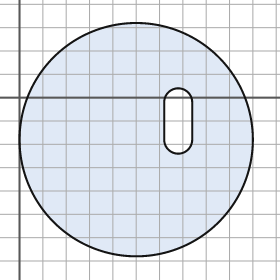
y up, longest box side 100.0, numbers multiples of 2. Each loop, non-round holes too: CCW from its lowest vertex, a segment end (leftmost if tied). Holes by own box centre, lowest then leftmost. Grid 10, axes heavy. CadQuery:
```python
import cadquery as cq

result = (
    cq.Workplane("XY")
    .moveTo(50.0, -18.0)
    .circle(50.0)
    .moveTo(62.0, -18.0)
    .threePointArc((68.0, -24.0), (74.0, -18.0))
    .lineTo(74.0, -2.0)
    .threePointArc((68.0, 4.0), (62.0, -2.0))
    .close()
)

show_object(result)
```